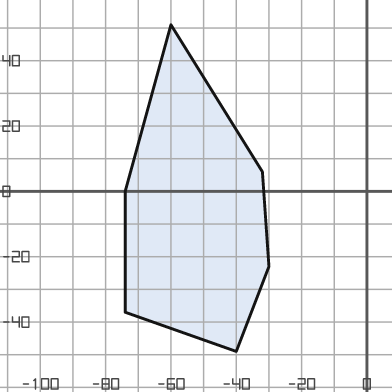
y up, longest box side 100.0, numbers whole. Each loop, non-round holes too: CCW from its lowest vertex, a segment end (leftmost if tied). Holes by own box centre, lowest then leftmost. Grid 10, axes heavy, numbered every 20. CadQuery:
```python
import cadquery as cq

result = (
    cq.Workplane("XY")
    .moveTo(-40.0, -49.0)
    .lineTo(-30.0, -23.0)
    .lineTo(-32.0, 6.0)
    .lineTo(-60.0, 51.0)
    .lineTo(-74.0, 0.0)
    .lineTo(-74.0, -37.0)
    .close()
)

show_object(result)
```